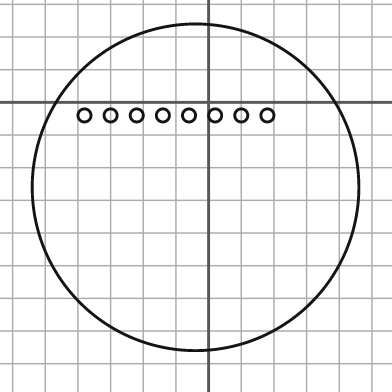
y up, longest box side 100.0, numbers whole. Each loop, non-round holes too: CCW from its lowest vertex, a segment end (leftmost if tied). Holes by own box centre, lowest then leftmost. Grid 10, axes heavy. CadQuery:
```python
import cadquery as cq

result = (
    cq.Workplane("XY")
    .moveTo(-4.0, -26.0)
    .circle(50.0)
    .moveTo(-38.0, -4.0)
    .circle(2.0)
    .moveTo(-30.0, -4.0)
    .circle(2.0)
    .moveTo(-22.0, -4.0)
    .circle(2.0)
    .moveTo(-14.0, -4.0)
    .circle(2.0)
    .moveTo(-6.0, -4.0)
    .circle(2.0)
    .moveTo(2.0, -4.0)
    .circle(2.0)
    .moveTo(10.0, -4.0)
    .circle(2.0)
    .moveTo(18.0, -4.0)
    .circle(2.0)
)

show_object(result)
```